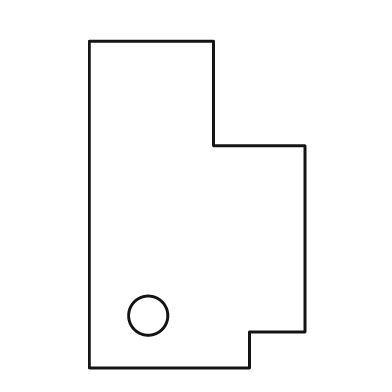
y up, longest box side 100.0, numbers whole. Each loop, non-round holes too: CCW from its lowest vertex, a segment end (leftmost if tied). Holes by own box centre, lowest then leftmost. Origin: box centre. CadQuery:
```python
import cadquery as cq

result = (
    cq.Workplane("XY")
    .moveTo(-33.0, -50.0)
    .lineTo(16.0, -50.0)
    .lineTo(16.0, -39.0)
    .lineTo(33.0, -39.0)
    .lineTo(33.0, 18.0)
    .lineTo(5.0, 18.0)
    .lineTo(5.0, 50.0)
    .lineTo(-33.0, 50.0)
    .close()
    .moveTo(-15.0, -34.0)
    .circle(6.0)
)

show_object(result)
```